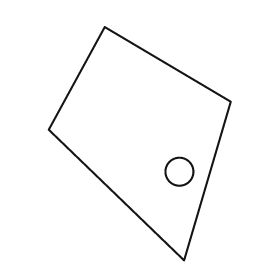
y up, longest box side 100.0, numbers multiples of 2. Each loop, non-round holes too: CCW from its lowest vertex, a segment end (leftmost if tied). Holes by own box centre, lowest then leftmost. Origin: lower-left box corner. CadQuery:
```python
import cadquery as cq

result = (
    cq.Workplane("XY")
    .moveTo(58.0, 0.0)
    .lineTo(78.0, 68.0)
    .lineTo(24.0, 100.0)
    .lineTo(0.0, 56.0)
    .close()
    .moveTo(56.0, 38.0)
    .circle(6.0)
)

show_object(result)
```